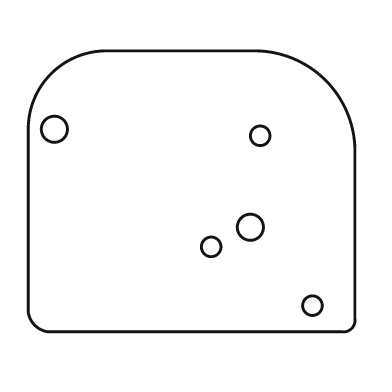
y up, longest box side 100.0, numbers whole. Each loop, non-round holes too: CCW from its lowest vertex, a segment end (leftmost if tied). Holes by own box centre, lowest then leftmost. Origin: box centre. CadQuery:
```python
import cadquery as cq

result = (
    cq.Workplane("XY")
    .moveTo(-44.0, -43.0)
    .lineTo(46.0, -43.0)
    .threePointArc((49.0, -42.0), (50.0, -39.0))
    .lineTo(50.0, 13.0)
    .threePointArc((41.0, 34.0), (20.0, 43.0))
    .lineTo(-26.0, 43.0)
    .threePointArc((-43.0, 36.0), (-50.0, 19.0))
    .lineTo(-50.0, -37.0)
    .threePointArc((-48.0, -41.0), (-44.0, -43.0))
    .close()
    .moveTo(37.0, -35.0)
    .circle(3.0)
    .moveTo(6.0, -17.0)
    .circle(3.0)
    .moveTo(18.0, -11.0)
    .circle(4.0)
    .moveTo(21.0, 17.0)
    .circle(3.0)
    .moveTo(-42.0, 19.0)
    .circle(4.0)
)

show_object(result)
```